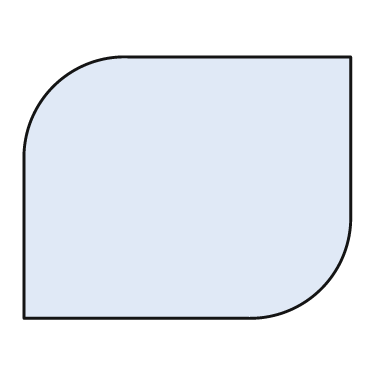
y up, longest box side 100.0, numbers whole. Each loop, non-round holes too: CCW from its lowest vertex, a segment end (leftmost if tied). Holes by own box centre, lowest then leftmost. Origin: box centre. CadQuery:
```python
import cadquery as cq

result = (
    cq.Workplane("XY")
    .moveTo(-50.0, -40.0)
    .lineTo(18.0, -40.0)
    .threePointArc((41.0, -31.0), (50.0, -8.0))
    .lineTo(50.0, 40.0)
    .lineTo(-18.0, 40.0)
    .threePointArc((-41.0, 31.0), (-50.0, 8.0))
    .close()
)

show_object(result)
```